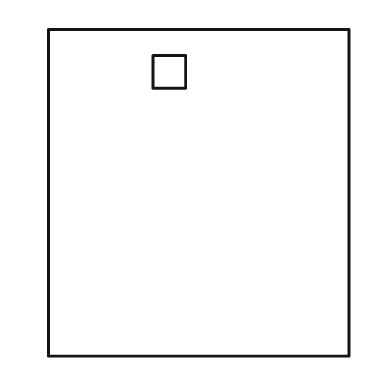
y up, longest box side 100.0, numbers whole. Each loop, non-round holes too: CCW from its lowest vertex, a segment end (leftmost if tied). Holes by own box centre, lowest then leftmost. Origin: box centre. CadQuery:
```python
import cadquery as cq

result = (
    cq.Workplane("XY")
    .moveTo(-46.0, -50.0)
    .lineTo(46.0, -50.0)
    .lineTo(46.0, 50.0)
    .lineTo(-46.0, 50.0)
    .close()
    .moveTo(-14.0, 32.0)
    .lineTo(-4.0, 32.0)
    .lineTo(-4.0, 42.0)
    .lineTo(-14.0, 42.0)
    .close()
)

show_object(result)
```